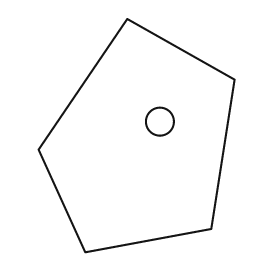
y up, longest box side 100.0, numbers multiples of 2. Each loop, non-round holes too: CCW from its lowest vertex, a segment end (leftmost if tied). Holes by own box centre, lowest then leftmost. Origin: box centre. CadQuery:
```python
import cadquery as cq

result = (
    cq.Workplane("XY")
    .moveTo(-22.0, -50.0)
    .lineTo(32.0, -40.0)
    .lineTo(42.0, 24.0)
    .lineTo(-4.0, 50.0)
    .lineTo(-42.0, -6.0)
    .close()
    .moveTo(10.0, 6.0)
    .circle(6.0)
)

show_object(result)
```